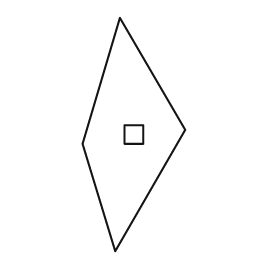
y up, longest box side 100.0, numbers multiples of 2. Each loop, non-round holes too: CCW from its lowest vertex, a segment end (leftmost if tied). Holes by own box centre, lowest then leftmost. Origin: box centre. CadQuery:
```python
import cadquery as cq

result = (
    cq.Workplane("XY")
    .moveTo(-8.0, -50.0)
    .lineTo(22.0, 2.0)
    .lineTo(-6.0, 50.0)
    .lineTo(-22.0, -4.0)
    .close()
    .moveTo(-4.0, -4.0)
    .lineTo(4.0, -4.0)
    .lineTo(4.0, 4.0)
    .lineTo(-4.0, 4.0)
    .close()
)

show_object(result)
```